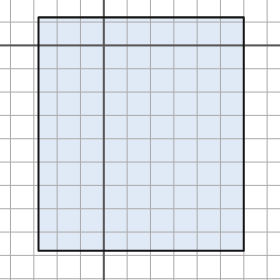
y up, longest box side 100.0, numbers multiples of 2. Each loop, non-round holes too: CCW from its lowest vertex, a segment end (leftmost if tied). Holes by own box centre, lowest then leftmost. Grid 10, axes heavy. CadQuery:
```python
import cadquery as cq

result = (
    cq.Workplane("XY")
    .moveTo(-28.0, -88.0)
    .lineTo(60.0, -88.0)
    .lineTo(60.0, 12.0)
    .lineTo(-28.0, 12.0)
    .close()
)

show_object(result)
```